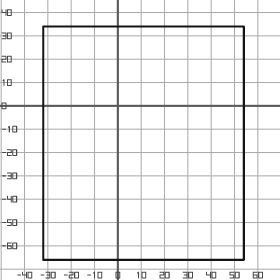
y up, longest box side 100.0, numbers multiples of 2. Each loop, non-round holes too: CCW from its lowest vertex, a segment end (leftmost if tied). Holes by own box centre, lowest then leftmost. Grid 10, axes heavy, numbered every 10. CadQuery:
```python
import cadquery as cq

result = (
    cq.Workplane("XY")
    .moveTo(-32.0, -66.0)
    .lineTo(54.0, -66.0)
    .lineTo(54.0, 34.0)
    .lineTo(-32.0, 34.0)
    .close()
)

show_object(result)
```